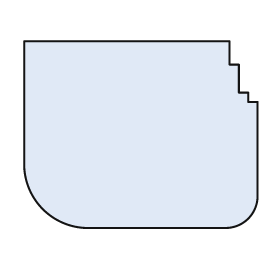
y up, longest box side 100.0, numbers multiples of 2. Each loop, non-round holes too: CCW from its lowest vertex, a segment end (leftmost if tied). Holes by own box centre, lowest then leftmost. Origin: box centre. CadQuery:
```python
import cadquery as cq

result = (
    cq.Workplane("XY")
    .moveTo(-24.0, -40.0)
    .lineTo(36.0, -40.0)
    .threePointArc((46.0, -36.0), (50.0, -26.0))
    .lineTo(50.0, 14.0)
    .lineTo(46.0, 14.0)
    .lineTo(46.0, 18.0)
    .lineTo(42.0, 18.0)
    .lineTo(42.0, 30.0)
    .lineTo(38.0, 30.0)
    .lineTo(38.0, 40.0)
    .lineTo(-50.0, 40.0)
    .lineTo(-50.0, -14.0)
    .threePointArc((-42.0, -32.0), (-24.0, -40.0))
    .close()
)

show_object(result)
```